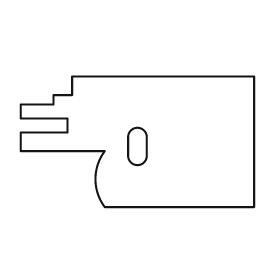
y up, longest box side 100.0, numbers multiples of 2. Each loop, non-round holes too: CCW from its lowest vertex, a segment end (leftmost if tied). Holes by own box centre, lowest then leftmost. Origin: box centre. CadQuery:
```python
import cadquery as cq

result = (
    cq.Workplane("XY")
    .moveTo(-14.0, -28.0)
    .lineTo(50.0, -28.0)
    .lineTo(50.0, 28.0)
    .lineTo(-28.0, 28.0)
    .lineTo(-28.0, 20.0)
    .lineTo(-36.0, 20.0)
    .lineTo(-36.0, 16.0)
    .lineTo(-50.0, 16.0)
    .lineTo(-50.0, 10.0)
    .lineTo(-30.0, 10.0)
    .lineTo(-30.0, 4.0)
    .lineTo(-50.0, 4.0)
    .lineTo(-50.0, -4.0)
    .lineTo(-14.0, -4.0)
    .threePointArc((-18.0, -16.0), (-14.0, -28.0))
    .close()
    .moveTo(-4.0, -6.0)
    .threePointArc((0.0, -10.0), (4.0, -6.0))
    .lineTo(4.0, 2.0)
    .threePointArc((0.0, 6.0), (-4.0, 2.0))
    .close()
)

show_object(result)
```